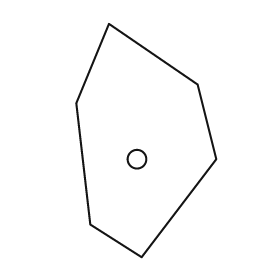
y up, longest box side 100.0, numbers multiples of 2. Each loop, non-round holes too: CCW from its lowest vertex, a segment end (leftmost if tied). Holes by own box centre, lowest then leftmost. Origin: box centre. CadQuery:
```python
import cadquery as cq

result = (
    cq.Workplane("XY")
    .moveTo(-2.0, -50.0)
    .lineTo(30.0, -8.0)
    .lineTo(22.0, 24.0)
    .lineTo(-16.0, 50.0)
    .lineTo(-30.0, 16.0)
    .lineTo(-24.0, -36.0)
    .close()
    .moveTo(-4.0, -8.0)
    .circle(4.0)
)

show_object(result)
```